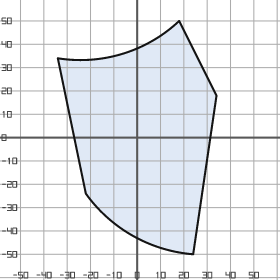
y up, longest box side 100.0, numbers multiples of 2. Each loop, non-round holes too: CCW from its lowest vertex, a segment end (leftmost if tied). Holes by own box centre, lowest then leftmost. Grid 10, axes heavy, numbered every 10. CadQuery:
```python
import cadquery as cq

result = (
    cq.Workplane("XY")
    .moveTo(24.0, -50.0)
    .lineTo(34.0, 18.0)
    .lineTo(18.0, 50.0)
    .threePointArc((-6.0, 36.0), (-34.0, 34.0))
    .lineTo(-22.0, -24.0)
    .threePointArc((-2.0, -42.0), (24.0, -50.0))
    .close()
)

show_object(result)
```